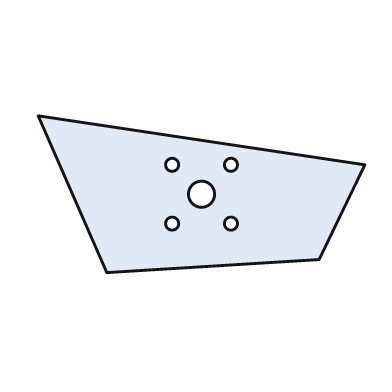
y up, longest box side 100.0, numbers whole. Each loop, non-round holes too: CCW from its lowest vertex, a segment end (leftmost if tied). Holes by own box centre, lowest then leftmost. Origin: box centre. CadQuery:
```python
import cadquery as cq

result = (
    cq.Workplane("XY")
    .moveTo(-29.0, -24.0)
    .lineTo(36.0, -20.0)
    .lineTo(50.0, 9.0)
    .lineTo(-50.0, 24.0)
    .close()
    .moveTo(-9.0, -9.0)
    .circle(2.0)
    .moveTo(9.0, -9.0)
    .circle(2.0)
    .moveTo(0.0, 0.0)
    .circle(4.0)
    .moveTo(-9.0, 9.0)
    .circle(2.0)
    .moveTo(9.0, 9.0)
    .circle(2.0)
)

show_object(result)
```